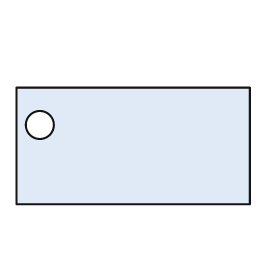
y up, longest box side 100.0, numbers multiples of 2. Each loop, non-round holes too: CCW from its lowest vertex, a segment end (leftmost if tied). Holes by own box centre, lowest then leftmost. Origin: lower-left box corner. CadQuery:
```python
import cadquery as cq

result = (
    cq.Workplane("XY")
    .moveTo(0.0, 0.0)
    .lineTo(100.0, 0.0)
    .lineTo(100.0, 50.0)
    .lineTo(0.0, 50.0)
    .close()
    .moveTo(10.0, 34.0)
    .circle(6.0)
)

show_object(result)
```